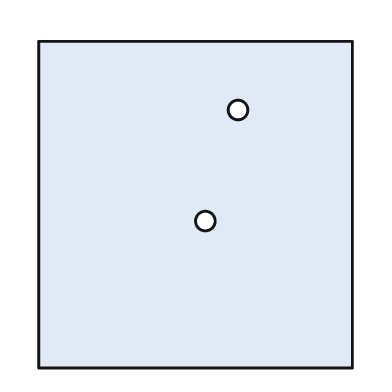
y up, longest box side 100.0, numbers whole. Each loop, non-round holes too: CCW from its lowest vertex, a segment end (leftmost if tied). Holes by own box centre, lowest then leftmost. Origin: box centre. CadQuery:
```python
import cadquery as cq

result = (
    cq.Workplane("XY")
    .moveTo(-48.0, -50.0)
    .lineTo(48.0, -50.0)
    .lineTo(48.0, 50.0)
    .lineTo(-48.0, 50.0)
    .close()
    .moveTo(3.0, -5.0)
    .circle(3.0)
    .moveTo(13.0, 29.0)
    .circle(3.0)
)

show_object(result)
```